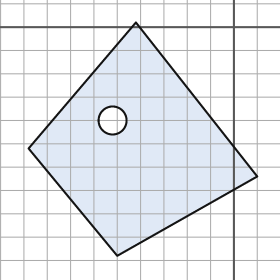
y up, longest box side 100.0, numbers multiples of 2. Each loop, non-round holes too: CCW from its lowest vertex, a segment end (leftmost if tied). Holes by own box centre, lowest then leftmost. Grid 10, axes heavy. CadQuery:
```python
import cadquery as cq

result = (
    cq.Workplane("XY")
    .moveTo(-50.0, -98.0)
    .lineTo(10.0, -64.0)
    .lineTo(-42.0, 2.0)
    .lineTo(-88.0, -52.0)
    .close()
    .moveTo(-52.0, -40.0)
    .circle(6.0)
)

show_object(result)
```